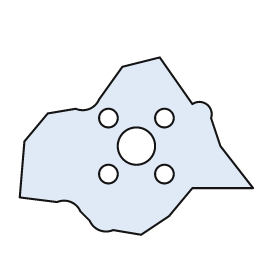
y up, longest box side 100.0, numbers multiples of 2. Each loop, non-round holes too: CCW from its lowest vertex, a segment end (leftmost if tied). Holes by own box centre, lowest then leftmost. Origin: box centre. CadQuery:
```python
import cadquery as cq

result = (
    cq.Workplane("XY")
    .moveTo(2.0, -38.0)
    .lineTo(14.0, -30.0)
    .lineTo(24.0, -18.0)
    .lineTo(50.0, -18.0)
    .lineTo(36.0, 0.0)
    .lineTo(32.0, 12.0)
    .threePointArc((30.0, 18.0), (24.0, 18.0))
    .lineTo(10.0, 38.0)
    .lineTo(-6.0, 34.0)
    .lineTo(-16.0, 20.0)
    .threePointArc((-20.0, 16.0), (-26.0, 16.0))
    .lineTo(-38.0, 14.0)
    .lineTo(-48.0, 2.0)
    .lineTo(-50.0, -22.0)
    .lineTo(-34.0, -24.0)
    .threePointArc((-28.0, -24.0), (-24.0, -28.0))
    .lineTo(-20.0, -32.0)
    .threePointArc((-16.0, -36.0), (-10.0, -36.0))
    .close()
    .moveTo(-12.0, -12.0)
    .circle(4.0)
    .moveTo(12.0, -12.0)
    .circle(4.0)
    .moveTo(0.0, 0.0)
    .circle(8.0)
    .moveTo(-12.0, 12.0)
    .circle(4.0)
    .moveTo(12.0, 12.0)
    .circle(4.0)
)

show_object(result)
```